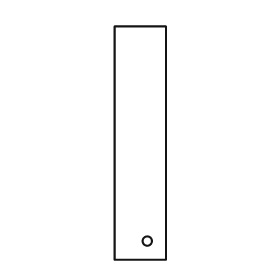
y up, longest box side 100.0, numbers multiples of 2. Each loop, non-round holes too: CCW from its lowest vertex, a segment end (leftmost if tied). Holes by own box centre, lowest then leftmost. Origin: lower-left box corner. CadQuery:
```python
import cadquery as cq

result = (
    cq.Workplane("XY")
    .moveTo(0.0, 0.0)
    .lineTo(22.0, 0.0)
    .lineTo(22.0, 100.0)
    .lineTo(0.0, 100.0)
    .close()
    .moveTo(14.0, 8.0)
    .circle(2.0)
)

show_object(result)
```